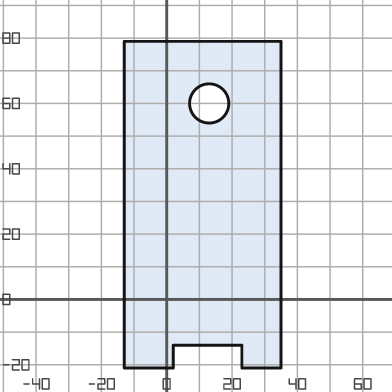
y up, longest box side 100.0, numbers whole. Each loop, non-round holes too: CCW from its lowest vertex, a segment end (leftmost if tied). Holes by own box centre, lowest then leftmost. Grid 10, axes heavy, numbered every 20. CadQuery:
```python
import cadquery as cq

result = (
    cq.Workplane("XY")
    .moveTo(-13.0, -21.0)
    .lineTo(2.0, -21.0)
    .lineTo(2.0, -14.0)
    .lineTo(23.0, -14.0)
    .lineTo(23.0, -21.0)
    .lineTo(35.0, -21.0)
    .lineTo(35.0, 79.0)
    .lineTo(-13.0, 79.0)
    .close()
    .moveTo(13.0, 60.0)
    .circle(6.0)
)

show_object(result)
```